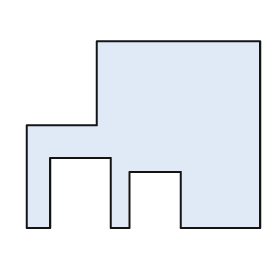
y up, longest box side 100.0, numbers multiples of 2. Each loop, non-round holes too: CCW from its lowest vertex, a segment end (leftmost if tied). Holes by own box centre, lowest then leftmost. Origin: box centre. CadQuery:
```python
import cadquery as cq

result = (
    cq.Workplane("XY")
    .moveTo(-50.0, -40.0)
    .lineTo(-40.0, -40.0)
    .lineTo(-40.0, -10.0)
    .lineTo(-14.0, -10.0)
    .lineTo(-14.0, -40.0)
    .lineTo(-6.0, -40.0)
    .lineTo(-6.0, -16.0)
    .lineTo(16.0, -16.0)
    .lineTo(16.0, -40.0)
    .lineTo(50.0, -40.0)
    .lineTo(50.0, 40.0)
    .lineTo(-20.0, 40.0)
    .lineTo(-20.0, 4.0)
    .lineTo(-50.0, 4.0)
    .close()
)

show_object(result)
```